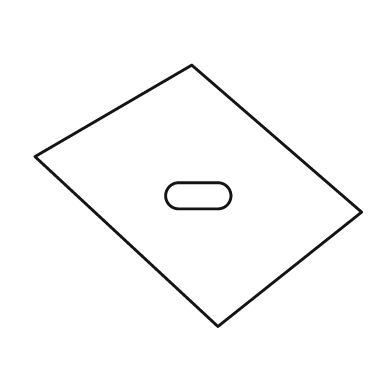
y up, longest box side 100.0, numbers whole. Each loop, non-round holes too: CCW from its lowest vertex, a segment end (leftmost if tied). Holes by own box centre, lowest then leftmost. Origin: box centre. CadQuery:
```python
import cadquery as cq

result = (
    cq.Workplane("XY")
    .moveTo(6.0, -40.0)
    .lineTo(50.0, -5.0)
    .lineTo(-2.0, 40.0)
    .lineTo(-50.0, 12.0)
    .close()
    .moveTo(-6.0, -4.0)
    .lineTo(6.0, -4.0)
    .threePointArc((10.0, 0.0), (6.0, 4.0))
    .lineTo(-6.0, 4.0)
    .threePointArc((-10.0, 0.0), (-6.0, -4.0))
    .close()
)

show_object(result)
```